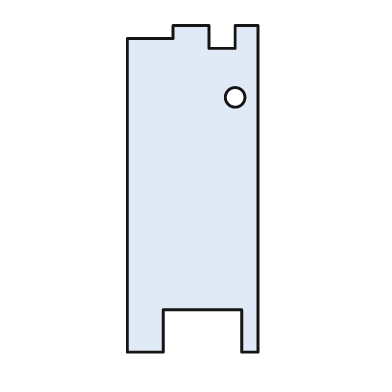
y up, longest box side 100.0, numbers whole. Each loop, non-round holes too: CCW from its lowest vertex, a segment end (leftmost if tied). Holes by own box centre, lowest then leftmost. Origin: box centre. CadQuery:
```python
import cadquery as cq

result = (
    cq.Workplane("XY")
    .moveTo(-20.0, -50.0)
    .lineTo(-9.0, -50.0)
    .lineTo(-9.0, -37.0)
    .lineTo(15.0, -37.0)
    .lineTo(15.0, -50.0)
    .lineTo(20.0, -50.0)
    .lineTo(20.0, 50.0)
    .lineTo(13.0, 50.0)
    .lineTo(13.0, 43.0)
    .lineTo(5.0, 43.0)
    .lineTo(5.0, 50.0)
    .lineTo(-6.0, 50.0)
    .lineTo(-6.0, 46.0)
    .lineTo(-20.0, 46.0)
    .close()
    .moveTo(13.0, 28.0)
    .circle(3.0)
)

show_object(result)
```